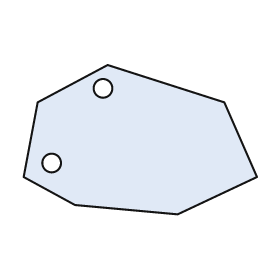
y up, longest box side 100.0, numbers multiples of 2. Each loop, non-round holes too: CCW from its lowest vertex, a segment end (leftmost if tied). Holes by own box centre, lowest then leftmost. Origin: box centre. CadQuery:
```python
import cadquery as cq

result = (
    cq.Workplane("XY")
    .moveTo(16.0, -32.0)
    .lineTo(50.0, -16.0)
    .lineTo(36.0, 16.0)
    .lineTo(-14.0, 32.0)
    .lineTo(-44.0, 16.0)
    .lineTo(-50.0, -16.0)
    .lineTo(-28.0, -28.0)
    .close()
    .moveTo(-38.0, -10.0)
    .circle(4.0)
    .moveTo(-16.0, 22.0)
    .circle(4.0)
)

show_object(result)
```